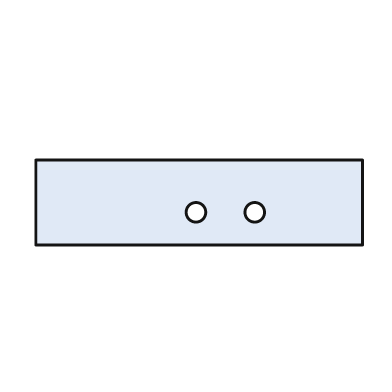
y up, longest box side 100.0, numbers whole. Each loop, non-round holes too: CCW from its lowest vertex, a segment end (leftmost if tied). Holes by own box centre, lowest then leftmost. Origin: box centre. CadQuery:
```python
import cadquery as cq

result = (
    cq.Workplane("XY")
    .moveTo(-50.0, -13.0)
    .lineTo(50.0, -13.0)
    .lineTo(50.0, 13.0)
    .lineTo(-50.0, 13.0)
    .close()
    .moveTo(-1.0, -3.0)
    .circle(3.0)
    .moveTo(17.0, -3.0)
    .circle(3.0)
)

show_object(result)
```